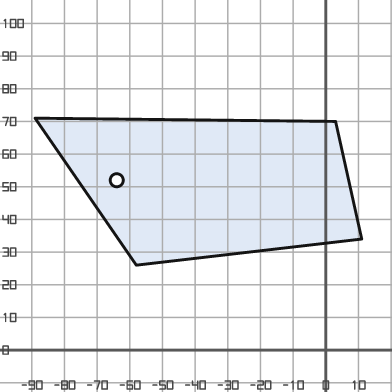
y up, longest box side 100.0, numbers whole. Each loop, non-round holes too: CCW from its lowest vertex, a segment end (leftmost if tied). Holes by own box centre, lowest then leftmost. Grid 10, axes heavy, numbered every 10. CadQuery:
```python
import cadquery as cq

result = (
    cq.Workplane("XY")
    .moveTo(-58.0, 26.0)
    .lineTo(11.0, 34.0)
    .lineTo(3.0, 70.0)
    .lineTo(-89.0, 71.0)
    .close()
    .moveTo(-64.0, 52.0)
    .circle(2.0)
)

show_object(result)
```